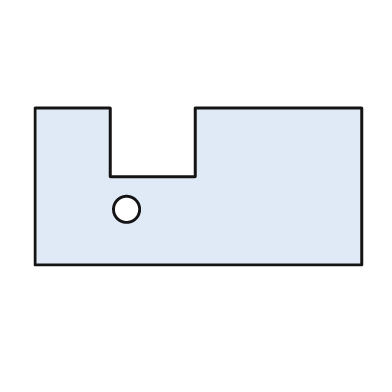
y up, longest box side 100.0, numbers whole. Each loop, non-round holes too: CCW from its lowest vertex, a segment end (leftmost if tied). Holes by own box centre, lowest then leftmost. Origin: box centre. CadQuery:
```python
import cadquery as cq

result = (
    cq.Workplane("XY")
    .moveTo(-50.0, -24.0)
    .lineTo(50.0, -24.0)
    .lineTo(50.0, 24.0)
    .lineTo(-1.0, 24.0)
    .lineTo(-1.0, 3.0)
    .lineTo(-27.0, 3.0)
    .lineTo(-27.0, 24.0)
    .lineTo(-50.0, 24.0)
    .close()
    .moveTo(-22.0, -7.0)
    .circle(4.0)
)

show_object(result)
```